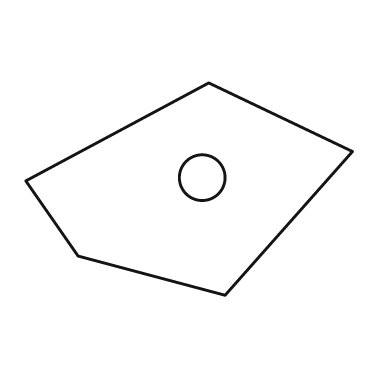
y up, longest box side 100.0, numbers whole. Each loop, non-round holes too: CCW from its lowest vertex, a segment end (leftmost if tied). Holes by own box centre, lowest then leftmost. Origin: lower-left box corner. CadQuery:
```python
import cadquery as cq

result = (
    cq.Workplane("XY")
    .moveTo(61.0, 0.0)
    .lineTo(100.0, 44.0)
    .lineTo(56.0, 65.0)
    .lineTo(0.0, 35.0)
    .lineTo(16.0, 12.0)
    .close()
    .moveTo(54.0, 36.0)
    .circle(7.0)
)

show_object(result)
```